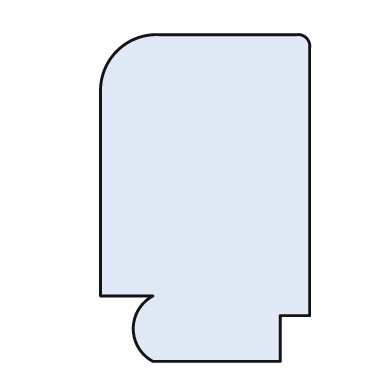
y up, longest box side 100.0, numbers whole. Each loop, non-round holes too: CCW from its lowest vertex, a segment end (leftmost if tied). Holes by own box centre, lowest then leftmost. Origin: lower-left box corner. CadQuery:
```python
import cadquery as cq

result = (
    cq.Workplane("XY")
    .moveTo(16.0, 0.0)
    .lineTo(55.0, 0.0)
    .lineTo(55.0, 14.0)
    .lineTo(64.0, 14.0)
    .lineTo(64.0, 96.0)
    .threePointArc((63.0, 99.0), (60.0, 100.0))
    .lineTo(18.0, 100.0)
    .threePointArc((5.0, 95.0), (0.0, 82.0))
    .lineTo(0.0, 20.0)
    .lineTo(16.0, 20.0)
    .threePointArc((10.0, 10.0), (16.0, 0.0))
    .close()
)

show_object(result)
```